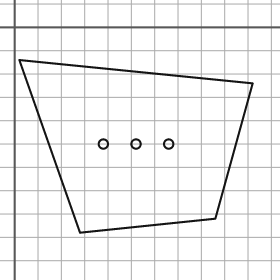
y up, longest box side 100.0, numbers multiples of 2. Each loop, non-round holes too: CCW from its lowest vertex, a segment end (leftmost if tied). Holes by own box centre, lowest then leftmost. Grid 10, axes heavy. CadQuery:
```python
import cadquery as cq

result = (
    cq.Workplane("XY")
    .moveTo(28.0, -88.0)
    .lineTo(86.0, -82.0)
    .lineTo(102.0, -24.0)
    .lineTo(2.0, -14.0)
    .close()
    .moveTo(38.0, -50.0)
    .circle(2.0)
    .moveTo(52.0, -50.0)
    .circle(2.0)
    .moveTo(66.0, -50.0)
    .circle(2.0)
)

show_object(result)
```